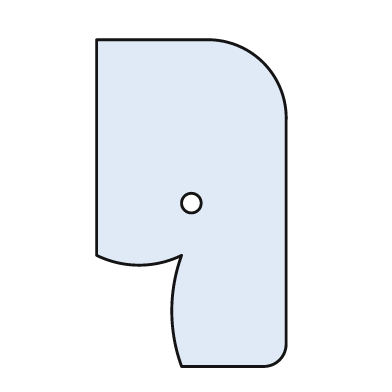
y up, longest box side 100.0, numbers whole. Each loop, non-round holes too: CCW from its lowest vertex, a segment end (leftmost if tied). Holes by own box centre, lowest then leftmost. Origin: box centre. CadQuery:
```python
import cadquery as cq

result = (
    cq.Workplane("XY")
    .moveTo(-3.0, -50.0)
    .lineTo(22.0, -50.0)
    .threePointArc((27.0, -48.0), (29.0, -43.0))
    .lineTo(29.0, 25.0)
    .threePointArc((22.0, 43.0), (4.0, 50.0))
    .lineTo(-29.0, 50.0)
    .lineTo(-29.0, -16.0)
    .threePointArc((-16.0, -19.0), (-3.0, -16.0))
    .threePointArc((-6.0, -33.0), (-3.0, -50.0))
    .close()
    .moveTo(0.0, 0.0)
    .circle(3.0)
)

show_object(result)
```